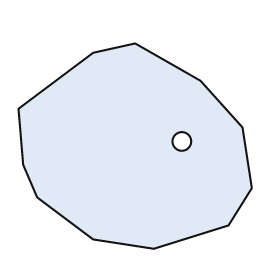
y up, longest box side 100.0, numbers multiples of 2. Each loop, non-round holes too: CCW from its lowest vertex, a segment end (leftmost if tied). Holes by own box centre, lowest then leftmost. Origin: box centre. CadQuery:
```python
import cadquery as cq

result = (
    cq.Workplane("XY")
    .moveTo(8.0, -44.0)
    .lineTo(40.0, -34.0)
    .lineTo(50.0, -18.0)
    .lineTo(46.0, 8.0)
    .lineTo(28.0, 28.0)
    .lineTo(0.0, 44.0)
    .lineTo(-18.0, 40.0)
    .lineTo(-50.0, 16.0)
    .lineTo(-48.0, -8.0)
    .lineTo(-42.0, -22.0)
    .lineTo(-18.0, -40.0)
    .close()
    .moveTo(20.0, 2.0)
    .circle(4.0)
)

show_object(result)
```